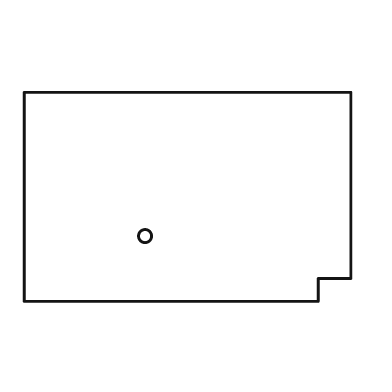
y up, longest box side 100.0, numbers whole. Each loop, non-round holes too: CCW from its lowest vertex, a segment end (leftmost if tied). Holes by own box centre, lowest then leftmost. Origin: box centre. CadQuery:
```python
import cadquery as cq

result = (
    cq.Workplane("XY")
    .moveTo(-50.0, -32.0)
    .lineTo(40.0, -32.0)
    .lineTo(40.0, -25.0)
    .lineTo(50.0, -25.0)
    .lineTo(50.0, 32.0)
    .lineTo(-50.0, 32.0)
    .close()
    .moveTo(-13.0, -12.0)
    .circle(2.0)
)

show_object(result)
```